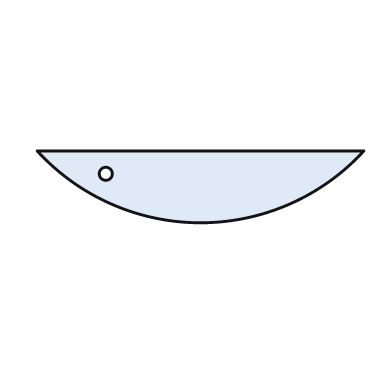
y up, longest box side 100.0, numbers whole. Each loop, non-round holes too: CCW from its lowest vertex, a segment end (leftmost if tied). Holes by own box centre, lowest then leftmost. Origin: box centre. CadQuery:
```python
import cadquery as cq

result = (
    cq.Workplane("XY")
    .moveTo(-50.0, 11.0)
    .threePointArc((0.0, -11.0), (50.0, 11.0))
    .close()
    .moveTo(-29.0, 4.0)
    .circle(2.0)
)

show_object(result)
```